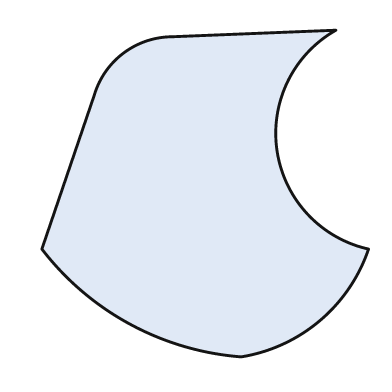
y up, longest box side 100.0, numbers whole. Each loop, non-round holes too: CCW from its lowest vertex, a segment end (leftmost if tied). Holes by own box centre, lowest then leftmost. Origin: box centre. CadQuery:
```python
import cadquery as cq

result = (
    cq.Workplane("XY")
    .moveTo(11.0, -50.0)
    .threePointArc((35.0, -39.0), (50.0, -17.0))
    .threePointArc((22.0, 13.0), (40.0, 50.0))
    .lineTo(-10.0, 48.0)
    .threePointArc((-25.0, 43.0), (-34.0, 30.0))
    .lineTo(-50.0, -17.0)
    .threePointArc((-23.0, -40.0), (11.0, -50.0))
    .close()
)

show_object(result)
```